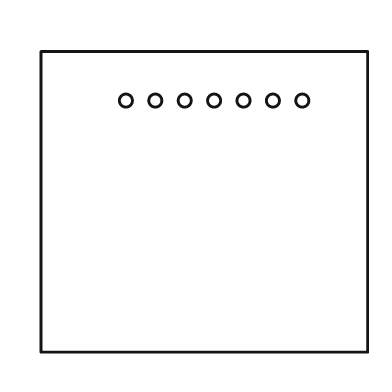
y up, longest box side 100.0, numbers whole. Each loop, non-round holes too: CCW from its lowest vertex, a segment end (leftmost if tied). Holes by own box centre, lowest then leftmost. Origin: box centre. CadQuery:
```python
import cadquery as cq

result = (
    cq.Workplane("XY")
    .moveTo(-50.0, -46.0)
    .lineTo(50.0, -46.0)
    .lineTo(50.0, 46.0)
    .lineTo(-50.0, 46.0)
    .close()
    .moveTo(-24.0, 31.0)
    .circle(2.0)
    .moveTo(-15.0, 31.0)
    .circle(2.0)
    .moveTo(-6.0, 31.0)
    .circle(2.0)
    .moveTo(3.0, 31.0)
    .circle(2.0)
    .moveTo(12.0, 31.0)
    .circle(2.0)
    .moveTo(21.0, 31.0)
    .circle(2.0)
    .moveTo(30.0, 31.0)
    .circle(2.0)
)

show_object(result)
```